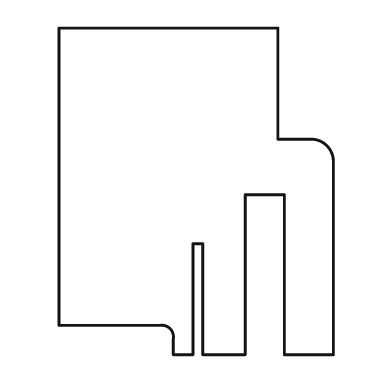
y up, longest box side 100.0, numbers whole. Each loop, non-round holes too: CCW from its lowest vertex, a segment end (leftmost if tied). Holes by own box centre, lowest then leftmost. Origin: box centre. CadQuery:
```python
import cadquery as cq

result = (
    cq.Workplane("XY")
    .moveTo(-7.0, -50.0)
    .lineTo(-1.0, -50.0)
    .lineTo(-1.0, -16.0)
    .lineTo(2.0, -16.0)
    .lineTo(2.0, -50.0)
    .lineTo(15.0, -50.0)
    .lineTo(15.0, -1.0)
    .lineTo(27.0, -1.0)
    .lineTo(27.0, -50.0)
    .lineTo(42.0, -50.0)
    .lineTo(42.0, 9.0)
    .threePointArc((40.0, 14.0), (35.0, 16.0))
    .lineTo(25.0, 16.0)
    .lineTo(25.0, 50.0)
    .lineTo(-42.0, 50.0)
    .lineTo(-42.0, -41.0)
    .lineTo(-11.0, -41.0)
    .threePointArc((-8.0, -42.0), (-7.0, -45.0))
    .close()
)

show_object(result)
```